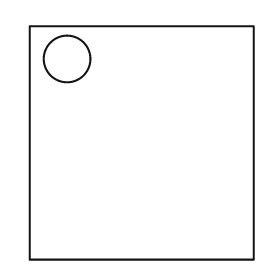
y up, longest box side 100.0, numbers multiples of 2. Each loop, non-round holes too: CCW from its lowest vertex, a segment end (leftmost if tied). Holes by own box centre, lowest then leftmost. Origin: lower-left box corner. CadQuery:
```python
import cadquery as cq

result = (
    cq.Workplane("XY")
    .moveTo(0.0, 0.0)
    .lineTo(96.0, 0.0)
    .lineTo(96.0, 100.0)
    .lineTo(0.0, 100.0)
    .close()
    .moveTo(16.0, 86.0)
    .circle(10.0)
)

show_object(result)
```